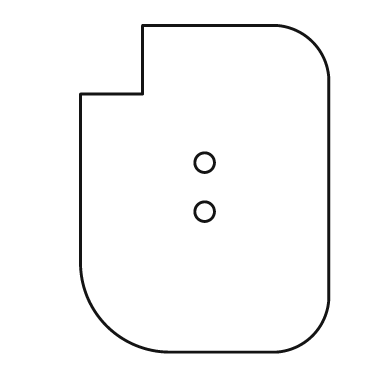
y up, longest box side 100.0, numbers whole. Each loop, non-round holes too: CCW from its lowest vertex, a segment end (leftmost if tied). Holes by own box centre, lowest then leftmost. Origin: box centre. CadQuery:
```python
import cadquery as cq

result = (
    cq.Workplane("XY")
    .moveTo(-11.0, -50.0)
    .lineTo(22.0, -50.0)
    .threePointArc((33.0, -45.0), (38.0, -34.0))
    .lineTo(38.0, 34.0)
    .threePointArc((33.0, 45.0), (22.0, 50.0))
    .lineTo(-19.0, 50.0)
    .lineTo(-19.0, 29.0)
    .lineTo(-38.0, 29.0)
    .lineTo(-38.0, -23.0)
    .threePointArc((-30.0, -42.0), (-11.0, -50.0))
    .close()
    .moveTo(0.0, -7.0)
    .circle(3.0)
    .moveTo(0.0, 8.0)
    .circle(3.0)
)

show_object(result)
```